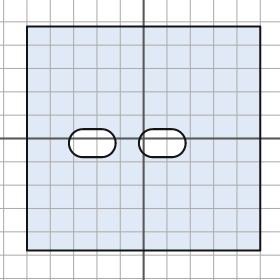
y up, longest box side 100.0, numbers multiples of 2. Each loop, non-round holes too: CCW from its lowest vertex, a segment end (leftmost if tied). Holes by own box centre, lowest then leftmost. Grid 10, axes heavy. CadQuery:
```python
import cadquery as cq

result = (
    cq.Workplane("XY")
    .moveTo(-50.0, -48.0)
    .lineTo(50.0, -48.0)
    .lineTo(50.0, 48.0)
    .lineTo(-50.0, 48.0)
    .close()
    .moveTo(-26.0, -8.0)
    .lineTo(-18.0, -8.0)
    .threePointArc((-12.0, -2.0), (-18.0, 4.0))
    .lineTo(-26.0, 4.0)
    .threePointArc((-32.0, -2.0), (-26.0, -8.0))
    .close()
    .moveTo(4.0, -8.0)
    .lineTo(12.0, -8.0)
    .threePointArc((18.0, -2.0), (12.0, 4.0))
    .lineTo(4.0, 4.0)
    .threePointArc((-2.0, -2.0), (4.0, -8.0))
    .close()
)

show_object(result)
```